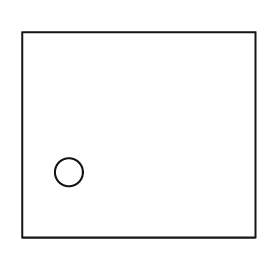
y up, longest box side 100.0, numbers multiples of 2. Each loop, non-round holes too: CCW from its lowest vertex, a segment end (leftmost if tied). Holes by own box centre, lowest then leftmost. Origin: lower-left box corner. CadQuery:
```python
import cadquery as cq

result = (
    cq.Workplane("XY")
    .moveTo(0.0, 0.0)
    .lineTo(100.0, 0.0)
    .lineTo(100.0, 88.0)
    .lineTo(0.0, 88.0)
    .close()
    .moveTo(20.0, 28.0)
    .circle(6.0)
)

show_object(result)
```